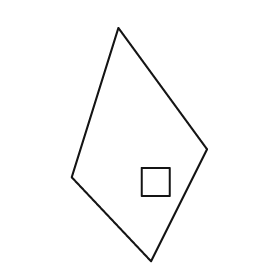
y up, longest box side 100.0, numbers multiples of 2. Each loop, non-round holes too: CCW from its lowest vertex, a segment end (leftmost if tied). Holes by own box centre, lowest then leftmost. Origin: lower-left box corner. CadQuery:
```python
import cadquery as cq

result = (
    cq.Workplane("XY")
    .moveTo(34.0, 0.0)
    .lineTo(58.0, 48.0)
    .lineTo(20.0, 100.0)
    .lineTo(0.0, 36.0)
    .close()
    .moveTo(30.0, 28.0)
    .lineTo(42.0, 28.0)
    .lineTo(42.0, 40.0)
    .lineTo(30.0, 40.0)
    .close()
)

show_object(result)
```